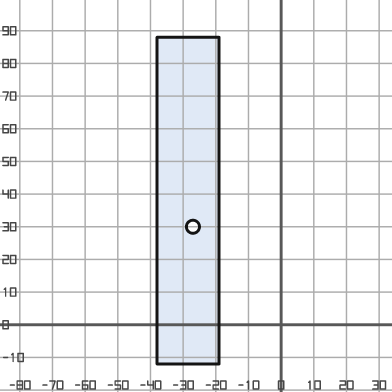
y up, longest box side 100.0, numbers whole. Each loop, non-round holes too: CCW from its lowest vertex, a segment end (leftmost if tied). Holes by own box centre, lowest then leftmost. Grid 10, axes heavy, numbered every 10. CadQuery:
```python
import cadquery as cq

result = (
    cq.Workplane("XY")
    .moveTo(-38.0, -12.0)
    .lineTo(-19.0, -12.0)
    .lineTo(-19.0, 88.0)
    .lineTo(-38.0, 88.0)
    .close()
    .moveTo(-27.0, 30.0)
    .circle(2.0)
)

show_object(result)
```